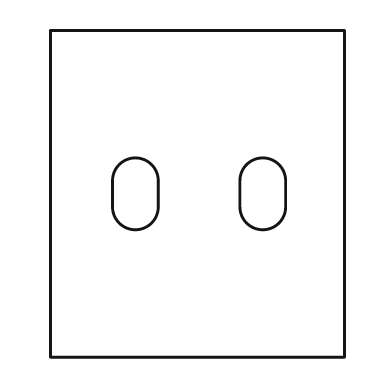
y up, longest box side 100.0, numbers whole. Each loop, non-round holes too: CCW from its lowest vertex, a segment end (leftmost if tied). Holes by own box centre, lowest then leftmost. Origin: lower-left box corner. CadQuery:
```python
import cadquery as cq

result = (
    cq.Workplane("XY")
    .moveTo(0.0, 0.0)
    .lineTo(90.0, 0.0)
    .lineTo(90.0, 100.0)
    .lineTo(0.0, 100.0)
    .close()
    .moveTo(19.0, 46.0)
    .threePointArc((26.0, 39.0), (33.0, 46.0))
    .lineTo(33.0, 54.0)
    .threePointArc((26.0, 61.0), (19.0, 54.0))
    .close()
    .moveTo(58.0, 46.0)
    .threePointArc((65.0, 39.0), (72.0, 46.0))
    .lineTo(72.0, 54.0)
    .threePointArc((65.0, 61.0), (58.0, 54.0))
    .close()
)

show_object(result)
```